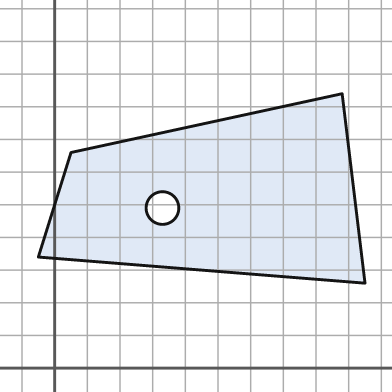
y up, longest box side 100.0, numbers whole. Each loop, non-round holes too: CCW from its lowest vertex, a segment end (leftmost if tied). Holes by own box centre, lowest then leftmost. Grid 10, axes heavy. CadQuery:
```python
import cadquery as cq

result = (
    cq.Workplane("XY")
    .moveTo(95.0, 26.0)
    .lineTo(88.0, 84.0)
    .lineTo(5.0, 66.0)
    .lineTo(-5.0, 34.0)
    .close()
    .moveTo(33.0, 49.0)
    .circle(5.0)
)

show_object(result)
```